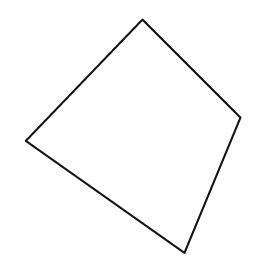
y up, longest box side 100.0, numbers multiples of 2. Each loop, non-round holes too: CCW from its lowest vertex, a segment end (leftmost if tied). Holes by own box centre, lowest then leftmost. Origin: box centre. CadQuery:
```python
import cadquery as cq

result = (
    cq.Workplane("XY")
    .moveTo(22.0, -50.0)
    .lineTo(46.0, 8.0)
    .lineTo(4.0, 50.0)
    .lineTo(-46.0, -2.0)
    .close()
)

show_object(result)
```